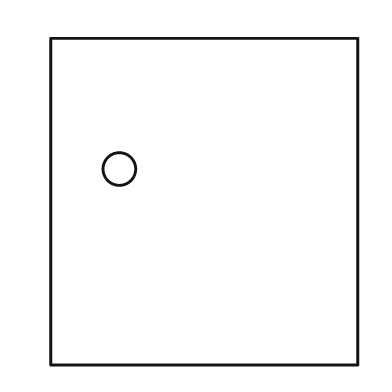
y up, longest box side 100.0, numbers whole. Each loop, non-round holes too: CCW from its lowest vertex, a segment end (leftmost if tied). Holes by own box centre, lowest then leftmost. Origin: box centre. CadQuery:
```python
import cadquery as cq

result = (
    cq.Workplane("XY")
    .moveTo(-47.0, -50.0)
    .lineTo(47.0, -50.0)
    .lineTo(47.0, 50.0)
    .lineTo(-47.0, 50.0)
    .close()
    .moveTo(-26.0, 10.0)
    .circle(5.0)
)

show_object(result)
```